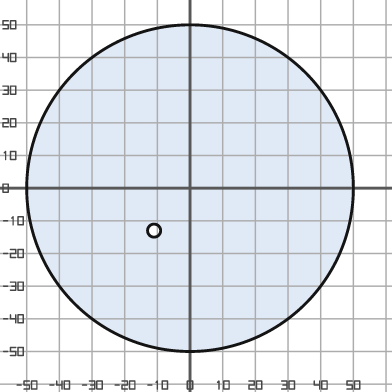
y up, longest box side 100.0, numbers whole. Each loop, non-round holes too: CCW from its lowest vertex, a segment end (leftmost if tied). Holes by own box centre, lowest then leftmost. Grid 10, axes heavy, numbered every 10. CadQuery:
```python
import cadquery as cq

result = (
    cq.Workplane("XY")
    .moveTo(0.0, 0.0)
    .circle(50.0)
    .moveTo(-11.0, -13.0)
    .circle(2.0)
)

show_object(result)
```